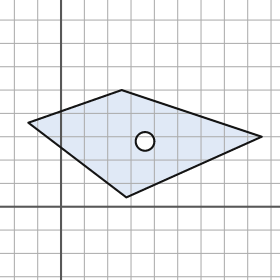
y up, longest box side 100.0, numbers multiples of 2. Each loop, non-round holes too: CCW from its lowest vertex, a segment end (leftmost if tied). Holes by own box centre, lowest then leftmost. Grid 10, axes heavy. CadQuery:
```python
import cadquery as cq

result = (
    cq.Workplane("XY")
    .moveTo(28.0, 4.0)
    .lineTo(86.0, 30.0)
    .lineTo(26.0, 50.0)
    .lineTo(-14.0, 36.0)
    .close()
    .moveTo(36.0, 28.0)
    .circle(4.0)
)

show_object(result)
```